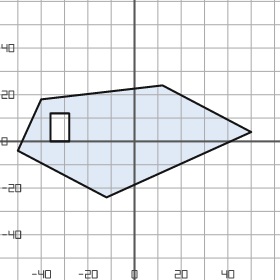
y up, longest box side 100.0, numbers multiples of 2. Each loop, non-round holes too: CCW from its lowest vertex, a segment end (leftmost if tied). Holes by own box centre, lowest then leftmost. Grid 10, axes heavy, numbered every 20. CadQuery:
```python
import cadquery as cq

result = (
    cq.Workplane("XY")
    .moveTo(-12.0, -24.0)
    .lineTo(50.0, 4.0)
    .lineTo(12.0, 24.0)
    .lineTo(-40.0, 18.0)
    .lineTo(-50.0, -4.0)
    .close()
    .moveTo(-36.0, 0.0)
    .lineTo(-28.0, 0.0)
    .lineTo(-28.0, 12.0)
    .lineTo(-36.0, 12.0)
    .close()
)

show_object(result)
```